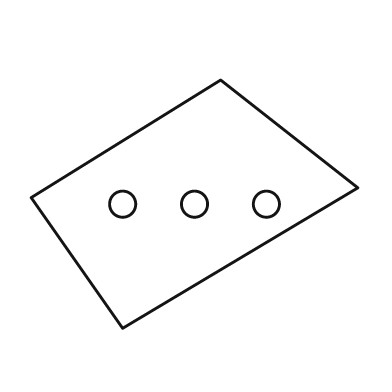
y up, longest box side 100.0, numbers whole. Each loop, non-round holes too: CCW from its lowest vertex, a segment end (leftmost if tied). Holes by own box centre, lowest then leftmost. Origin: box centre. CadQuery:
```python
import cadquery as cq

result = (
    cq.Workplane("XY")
    .moveTo(-22.0, -38.0)
    .lineTo(50.0, 5.0)
    .lineTo(8.0, 38.0)
    .lineTo(-50.0, 2.0)
    .close()
    .moveTo(-22.0, 0.0)
    .circle(4.0)
    .moveTo(0.0, 0.0)
    .circle(4.0)
    .moveTo(22.0, 0.0)
    .circle(4.0)
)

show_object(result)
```